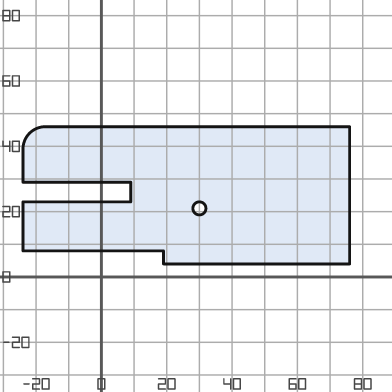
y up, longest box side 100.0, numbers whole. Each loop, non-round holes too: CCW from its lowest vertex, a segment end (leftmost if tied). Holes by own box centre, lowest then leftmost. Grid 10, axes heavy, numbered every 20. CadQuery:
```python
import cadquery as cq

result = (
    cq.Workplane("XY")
    .moveTo(19.0, 4.0)
    .lineTo(76.0, 4.0)
    .lineTo(76.0, 46.0)
    .lineTo(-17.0, 46.0)
    .threePointArc((-22.0, 44.0), (-24.0, 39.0))
    .lineTo(-24.0, 29.0)
    .lineTo(9.0, 29.0)
    .lineTo(9.0, 23.0)
    .lineTo(-24.0, 23.0)
    .lineTo(-24.0, 8.0)
    .lineTo(19.0, 8.0)
    .close()
    .moveTo(30.0, 21.0)
    .circle(2.0)
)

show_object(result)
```